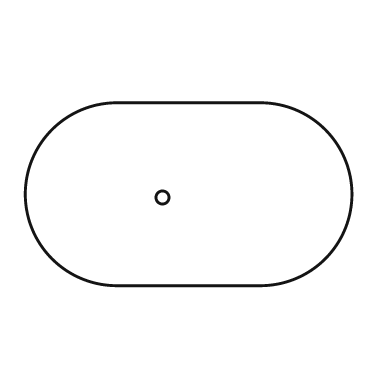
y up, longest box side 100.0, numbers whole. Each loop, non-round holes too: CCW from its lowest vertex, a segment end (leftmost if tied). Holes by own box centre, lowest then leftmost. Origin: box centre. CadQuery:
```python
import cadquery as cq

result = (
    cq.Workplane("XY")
    .moveTo(-22.0, -28.0)
    .lineTo(22.0, -28.0)
    .threePointArc((50.0, 0.0), (22.0, 28.0))
    .lineTo(-22.0, 28.0)
    .threePointArc((-50.0, 0.0), (-22.0, -28.0))
    .close()
    .moveTo(-8.0, -1.0)
    .circle(2.0)
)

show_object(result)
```